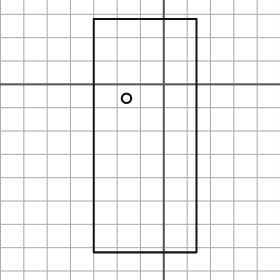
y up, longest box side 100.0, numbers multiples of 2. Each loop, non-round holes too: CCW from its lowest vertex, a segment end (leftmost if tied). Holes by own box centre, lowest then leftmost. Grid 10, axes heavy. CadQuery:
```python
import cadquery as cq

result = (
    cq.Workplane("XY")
    .moveTo(-30.0, -72.0)
    .lineTo(14.0, -72.0)
    .lineTo(14.0, 28.0)
    .lineTo(-30.0, 28.0)
    .close()
    .moveTo(-16.0, -6.0)
    .circle(2.0)
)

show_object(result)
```